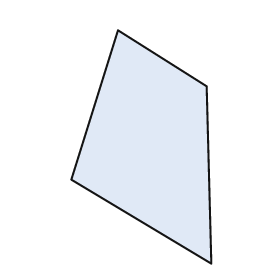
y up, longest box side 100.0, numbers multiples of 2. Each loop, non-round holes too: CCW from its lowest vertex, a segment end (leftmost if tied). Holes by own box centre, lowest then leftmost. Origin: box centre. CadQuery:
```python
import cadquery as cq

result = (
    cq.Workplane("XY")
    .moveTo(30.0, -50.0)
    .lineTo(28.0, 26.0)
    .lineTo(-10.0, 50.0)
    .lineTo(-30.0, -14.0)
    .close()
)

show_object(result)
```